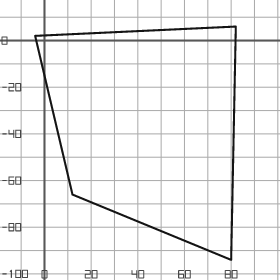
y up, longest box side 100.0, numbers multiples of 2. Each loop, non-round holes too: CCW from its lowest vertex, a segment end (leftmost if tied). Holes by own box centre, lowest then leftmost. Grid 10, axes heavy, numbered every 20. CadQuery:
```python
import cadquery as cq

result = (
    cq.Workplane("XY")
    .moveTo(80.0, -94.0)
    .lineTo(82.0, 6.0)
    .lineTo(-4.0, 2.0)
    .lineTo(12.0, -66.0)
    .close()
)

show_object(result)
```